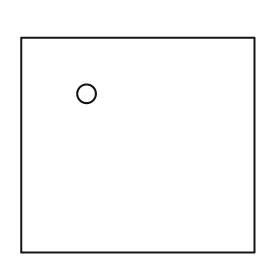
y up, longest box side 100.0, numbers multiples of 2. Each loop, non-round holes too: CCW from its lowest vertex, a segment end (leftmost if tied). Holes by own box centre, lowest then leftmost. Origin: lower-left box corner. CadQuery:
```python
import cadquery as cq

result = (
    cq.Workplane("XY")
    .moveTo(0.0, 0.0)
    .lineTo(100.0, 0.0)
    .lineTo(100.0, 92.0)
    .lineTo(0.0, 92.0)
    .close()
    .moveTo(28.0, 68.0)
    .circle(4.0)
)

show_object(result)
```